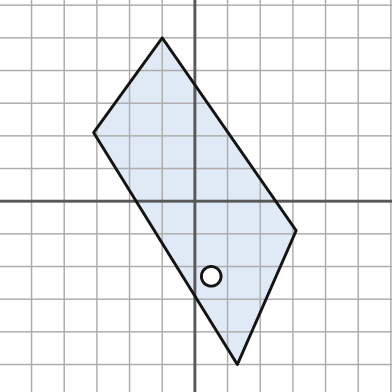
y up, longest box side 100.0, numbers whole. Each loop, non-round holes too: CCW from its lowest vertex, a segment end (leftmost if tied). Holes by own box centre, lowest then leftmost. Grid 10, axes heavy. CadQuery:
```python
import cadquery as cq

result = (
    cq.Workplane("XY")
    .moveTo(13.0, -50.0)
    .lineTo(31.0, -9.0)
    .lineTo(-10.0, 50.0)
    .lineTo(-31.0, 21.0)
    .close()
    .moveTo(5.0, -23.0)
    .circle(3.0)
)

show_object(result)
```